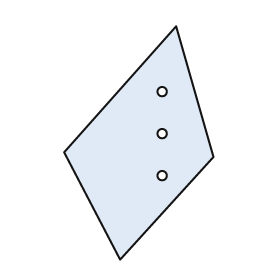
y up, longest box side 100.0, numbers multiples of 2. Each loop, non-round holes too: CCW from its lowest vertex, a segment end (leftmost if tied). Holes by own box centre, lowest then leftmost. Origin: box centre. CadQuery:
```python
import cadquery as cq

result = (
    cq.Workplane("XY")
    .moveTo(-8.0, -50.0)
    .lineTo(32.0, -6.0)
    .lineTo(16.0, 50.0)
    .lineTo(-32.0, -4.0)
    .close()
    .moveTo(10.0, -14.0)
    .circle(2.0)
    .moveTo(10.0, 4.0)
    .circle(2.0)
    .moveTo(10.0, 22.0)
    .circle(2.0)
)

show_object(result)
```